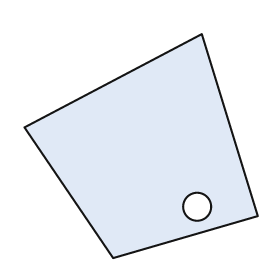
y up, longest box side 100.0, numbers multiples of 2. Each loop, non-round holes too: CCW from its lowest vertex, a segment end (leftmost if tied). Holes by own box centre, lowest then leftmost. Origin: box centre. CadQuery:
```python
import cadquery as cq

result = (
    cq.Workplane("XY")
    .moveTo(-12.0, -48.0)
    .lineTo(50.0, -30.0)
    .lineTo(26.0, 48.0)
    .lineTo(-50.0, 8.0)
    .close()
    .moveTo(24.0, -26.0)
    .circle(6.0)
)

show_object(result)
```